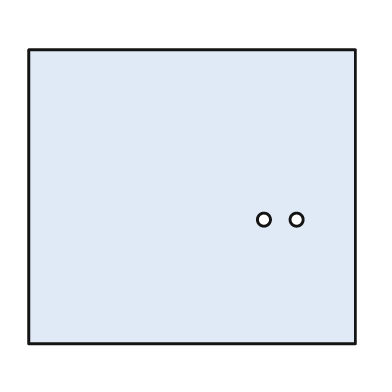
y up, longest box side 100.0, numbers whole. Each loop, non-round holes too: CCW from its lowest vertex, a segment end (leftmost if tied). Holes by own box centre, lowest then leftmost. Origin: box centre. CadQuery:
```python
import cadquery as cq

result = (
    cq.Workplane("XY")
    .moveTo(-50.0, -45.0)
    .lineTo(50.0, -45.0)
    .lineTo(50.0, 45.0)
    .lineTo(-50.0, 45.0)
    .close()
    .moveTo(22.0, -7.0)
    .circle(2.0)
    .moveTo(32.0, -7.0)
    .circle(2.0)
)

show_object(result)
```